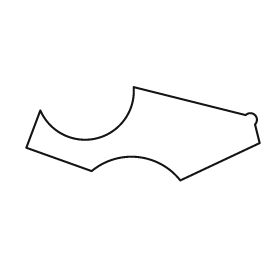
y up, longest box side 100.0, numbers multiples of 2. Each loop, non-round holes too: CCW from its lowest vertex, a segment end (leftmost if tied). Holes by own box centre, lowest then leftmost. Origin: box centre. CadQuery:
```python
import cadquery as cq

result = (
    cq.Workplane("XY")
    .moveTo(16.0, -20.0)
    .lineTo(50.0, -4.0)
    .lineTo(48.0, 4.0)
    .threePointArc((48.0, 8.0), (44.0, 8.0))
    .lineTo(-4.0, 20.0)
    .threePointArc((-20.0, -2.0), (-44.0, 10.0))
    .lineTo(-50.0, -6.0)
    .lineTo(-22.0, -16.0)
    .threePointArc((-2.0, -10.0), (16.0, -20.0))
    .close()
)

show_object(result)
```